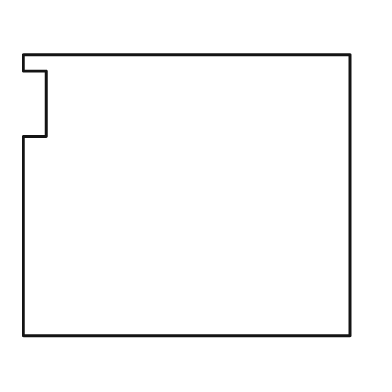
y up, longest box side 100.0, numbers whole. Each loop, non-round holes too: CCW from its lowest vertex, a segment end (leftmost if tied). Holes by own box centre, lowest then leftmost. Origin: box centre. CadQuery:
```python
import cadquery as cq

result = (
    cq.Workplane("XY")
    .moveTo(-50.0, -43.0)
    .lineTo(50.0, -43.0)
    .lineTo(50.0, 43.0)
    .lineTo(-50.0, 43.0)
    .lineTo(-50.0, 38.0)
    .lineTo(-43.0, 38.0)
    .lineTo(-43.0, 18.0)
    .lineTo(-50.0, 18.0)
    .close()
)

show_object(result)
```